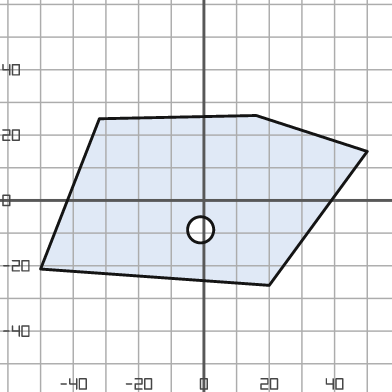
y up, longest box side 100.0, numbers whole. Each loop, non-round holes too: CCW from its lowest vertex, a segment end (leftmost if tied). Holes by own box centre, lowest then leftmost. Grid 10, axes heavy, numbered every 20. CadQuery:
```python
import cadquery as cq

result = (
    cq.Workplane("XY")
    .moveTo(20.0, -26.0)
    .lineTo(50.0, 15.0)
    .lineTo(16.0, 26.0)
    .lineTo(-32.0, 25.0)
    .lineTo(-50.0, -21.0)
    .close()
    .moveTo(-1.0, -9.0)
    .circle(4.0)
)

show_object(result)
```